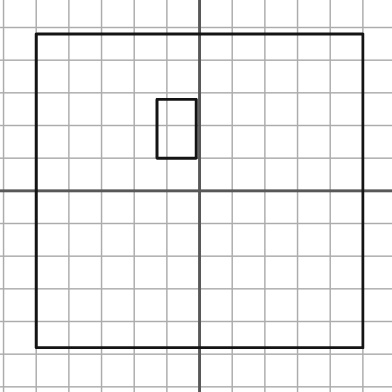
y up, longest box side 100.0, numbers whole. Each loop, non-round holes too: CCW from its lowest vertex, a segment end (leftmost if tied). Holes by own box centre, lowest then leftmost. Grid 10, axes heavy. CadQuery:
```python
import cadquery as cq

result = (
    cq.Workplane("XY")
    .moveTo(-50.0, -48.0)
    .lineTo(50.0, -48.0)
    .lineTo(50.0, 48.0)
    .lineTo(-50.0, 48.0)
    .close()
    .moveTo(-13.0, 10.0)
    .lineTo(-1.0, 10.0)
    .lineTo(-1.0, 28.0)
    .lineTo(-13.0, 28.0)
    .close()
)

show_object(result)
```